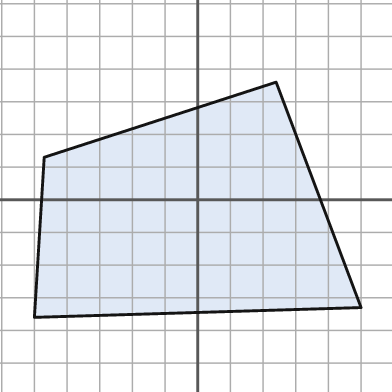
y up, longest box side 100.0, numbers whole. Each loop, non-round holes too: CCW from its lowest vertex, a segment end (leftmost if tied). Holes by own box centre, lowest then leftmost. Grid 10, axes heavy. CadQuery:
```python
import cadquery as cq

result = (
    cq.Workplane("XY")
    .moveTo(-50.0, -36.0)
    .lineTo(50.0, -33.0)
    .lineTo(24.0, 36.0)
    .lineTo(-47.0, 13.0)
    .close()
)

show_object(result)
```